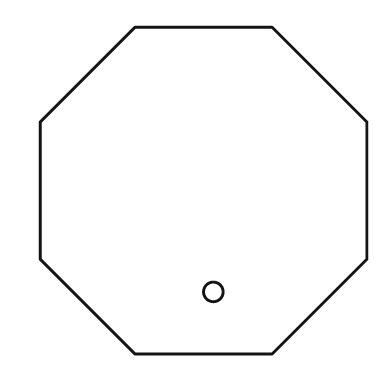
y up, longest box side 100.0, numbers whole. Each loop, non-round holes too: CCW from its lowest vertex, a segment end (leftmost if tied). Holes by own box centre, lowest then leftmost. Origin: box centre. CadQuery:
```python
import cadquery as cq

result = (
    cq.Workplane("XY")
    .moveTo(-21.0, -50.0)
    .lineTo(21.0, -50.0)
    .lineTo(50.0, -21.0)
    .lineTo(50.0, 21.0)
    .lineTo(21.0, 50.0)
    .lineTo(-21.0, 50.0)
    .lineTo(-50.0, 21.0)
    .lineTo(-50.0, -21.0)
    .close()
    .moveTo(3.0, -31.0)
    .circle(3.0)
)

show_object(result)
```